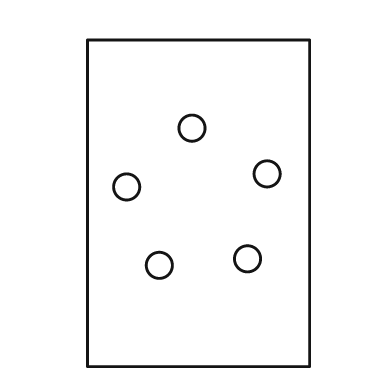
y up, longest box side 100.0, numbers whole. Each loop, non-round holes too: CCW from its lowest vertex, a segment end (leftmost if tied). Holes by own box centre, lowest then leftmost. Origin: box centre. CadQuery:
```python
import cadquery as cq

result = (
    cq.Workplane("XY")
    .moveTo(-34.0, -50.0)
    .lineTo(34.0, -50.0)
    .lineTo(34.0, 50.0)
    .lineTo(-34.0, 50.0)
    .close()
    .moveTo(-12.0, -19.0)
    .circle(4.0)
    .moveTo(15.0, -17.0)
    .circle(4.0)
    .moveTo(-22.0, 5.0)
    .circle(4.0)
    .moveTo(21.0, 9.0)
    .circle(4.0)
    .moveTo(-2.0, 23.0)
    .circle(4.0)
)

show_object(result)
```